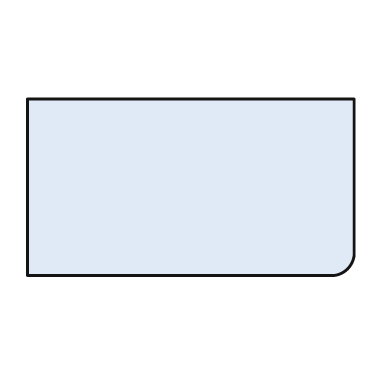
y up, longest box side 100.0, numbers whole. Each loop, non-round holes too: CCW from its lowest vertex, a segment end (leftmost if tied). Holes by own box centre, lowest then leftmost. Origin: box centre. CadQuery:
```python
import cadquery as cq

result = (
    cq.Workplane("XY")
    .moveTo(-50.0, -27.0)
    .lineTo(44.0, -27.0)
    .threePointArc((48.0, -25.0), (50.0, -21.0))
    .lineTo(50.0, 27.0)
    .lineTo(-50.0, 27.0)
    .close()
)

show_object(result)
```